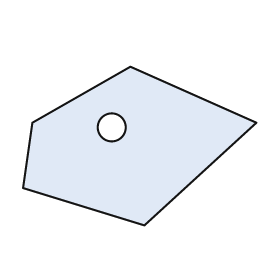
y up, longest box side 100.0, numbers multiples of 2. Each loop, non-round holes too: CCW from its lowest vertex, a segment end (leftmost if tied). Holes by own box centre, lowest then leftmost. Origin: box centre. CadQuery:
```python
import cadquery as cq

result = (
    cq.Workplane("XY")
    .moveTo(2.0, -34.0)
    .lineTo(50.0, 10.0)
    .lineTo(-4.0, 34.0)
    .lineTo(-46.0, 10.0)
    .lineTo(-50.0, -18.0)
    .close()
    .moveTo(-12.0, 8.0)
    .circle(6.0)
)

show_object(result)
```